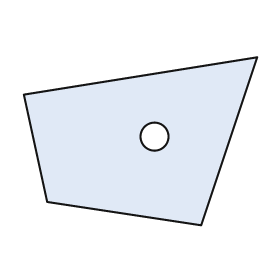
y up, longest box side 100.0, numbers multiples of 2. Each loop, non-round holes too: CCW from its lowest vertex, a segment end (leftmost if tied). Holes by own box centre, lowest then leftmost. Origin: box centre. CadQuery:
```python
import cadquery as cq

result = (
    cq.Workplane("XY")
    .moveTo(26.0, -36.0)
    .lineTo(50.0, 36.0)
    .lineTo(-50.0, 20.0)
    .lineTo(-40.0, -26.0)
    .close()
    .moveTo(6.0, 2.0)
    .circle(6.0)
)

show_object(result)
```